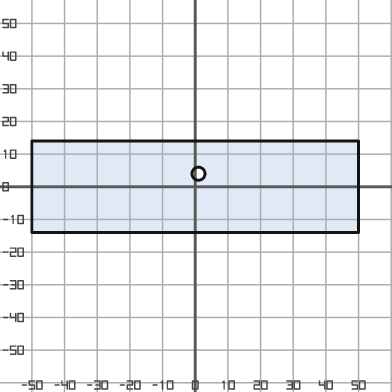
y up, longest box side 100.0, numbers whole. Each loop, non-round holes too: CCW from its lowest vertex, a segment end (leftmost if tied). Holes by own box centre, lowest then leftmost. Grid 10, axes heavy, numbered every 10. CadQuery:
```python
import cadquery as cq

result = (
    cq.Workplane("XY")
    .moveTo(-50.0, -14.0)
    .lineTo(50.0, -14.0)
    .lineTo(50.0, 14.0)
    .lineTo(-50.0, 14.0)
    .close()
    .moveTo(1.0, 4.0)
    .circle(2.0)
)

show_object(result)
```